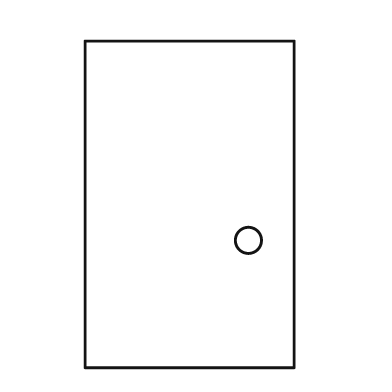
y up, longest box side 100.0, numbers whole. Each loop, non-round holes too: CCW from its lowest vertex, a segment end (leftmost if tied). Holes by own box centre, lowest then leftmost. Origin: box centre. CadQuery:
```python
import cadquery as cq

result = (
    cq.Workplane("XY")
    .moveTo(-32.0, -50.0)
    .lineTo(32.0, -50.0)
    .lineTo(32.0, 50.0)
    .lineTo(-32.0, 50.0)
    .close()
    .moveTo(18.0, -11.0)
    .circle(4.0)
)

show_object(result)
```